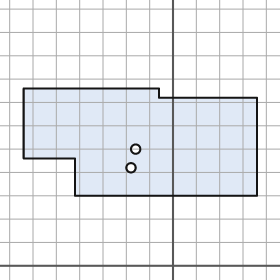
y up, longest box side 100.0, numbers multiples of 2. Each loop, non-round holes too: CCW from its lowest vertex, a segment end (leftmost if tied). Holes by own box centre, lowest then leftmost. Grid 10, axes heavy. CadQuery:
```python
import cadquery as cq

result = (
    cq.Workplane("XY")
    .moveTo(-42.0, 30.0)
    .lineTo(36.0, 30.0)
    .lineTo(36.0, 72.0)
    .lineTo(-6.0, 72.0)
    .lineTo(-6.0, 76.0)
    .lineTo(-64.0, 76.0)
    .lineTo(-64.0, 46.0)
    .lineTo(-42.0, 46.0)
    .close()
    .moveTo(-18.0, 42.0)
    .circle(2.0)
    .moveTo(-16.0, 50.0)
    .circle(2.0)
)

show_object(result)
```